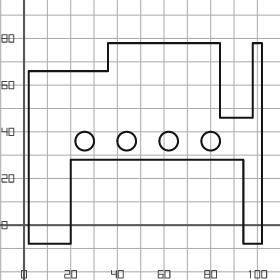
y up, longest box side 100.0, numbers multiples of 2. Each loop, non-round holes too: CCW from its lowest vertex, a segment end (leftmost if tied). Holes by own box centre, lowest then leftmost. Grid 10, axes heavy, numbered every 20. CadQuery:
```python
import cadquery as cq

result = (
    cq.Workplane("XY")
    .moveTo(2.0, -8.0)
    .lineTo(20.0, -8.0)
    .lineTo(20.0, 28.0)
    .lineTo(94.0, 28.0)
    .lineTo(94.0, -8.0)
    .lineTo(102.0, -8.0)
    .lineTo(102.0, 78.0)
    .lineTo(98.0, 78.0)
    .lineTo(98.0, 46.0)
    .lineTo(84.0, 46.0)
    .lineTo(84.0, 78.0)
    .lineTo(36.0, 78.0)
    .lineTo(36.0, 66.0)
    .lineTo(2.0, 66.0)
    .close()
    .moveTo(26.0, 36.0)
    .circle(4.0)
    .moveTo(44.0, 36.0)
    .circle(4.0)
    .moveTo(62.0, 36.0)
    .circle(4.0)
    .moveTo(80.0, 36.0)
    .circle(4.0)
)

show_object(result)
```